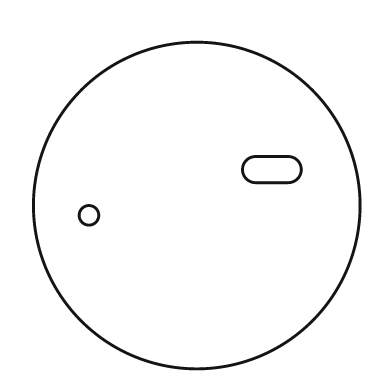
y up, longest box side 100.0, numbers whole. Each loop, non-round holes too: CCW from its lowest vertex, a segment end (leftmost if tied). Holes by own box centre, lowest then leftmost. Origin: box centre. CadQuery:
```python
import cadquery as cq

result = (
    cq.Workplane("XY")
    .moveTo(0.0, 0.0)
    .circle(50.0)
    .moveTo(-33.0, -3.0)
    .circle(3.0)
    .moveTo(18.0, 7.0)
    .lineTo(28.0, 7.0)
    .threePointArc((32.0, 11.0), (28.0, 15.0))
    .lineTo(18.0, 15.0)
    .threePointArc((14.0, 11.0), (18.0, 7.0))
    .close()
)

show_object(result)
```